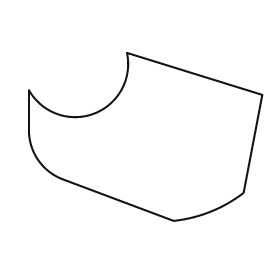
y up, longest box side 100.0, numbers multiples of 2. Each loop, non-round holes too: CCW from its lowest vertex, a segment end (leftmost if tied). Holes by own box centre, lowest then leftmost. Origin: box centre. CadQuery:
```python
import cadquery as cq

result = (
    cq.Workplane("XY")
    .moveTo(12.0, -36.0)
    .threePointArc((28.0, -32.0), (42.0, -24.0))
    .lineTo(50.0, 18.0)
    .lineTo(-8.0, 36.0)
    .threePointArc((-22.0, 10.0), (-50.0, 20.0))
    .lineTo(-50.0, 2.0)
    .threePointArc((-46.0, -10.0), (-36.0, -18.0))
    .close()
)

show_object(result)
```